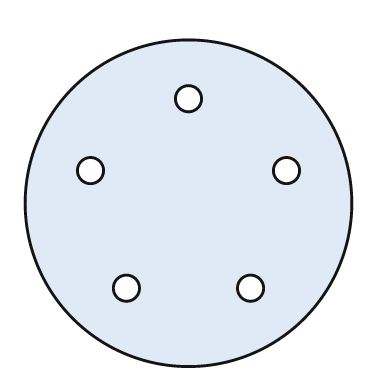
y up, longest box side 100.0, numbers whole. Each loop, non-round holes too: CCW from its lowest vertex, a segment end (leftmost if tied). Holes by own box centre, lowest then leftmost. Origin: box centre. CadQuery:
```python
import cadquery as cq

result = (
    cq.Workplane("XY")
    .moveTo(0.0, 0.0)
    .circle(50.0)
    .moveTo(-19.0, -26.0)
    .circle(4.0)
    .moveTo(19.0, -26.0)
    .circle(4.0)
    .moveTo(-30.0, 10.0)
    .circle(4.0)
    .moveTo(30.0, 10.0)
    .circle(4.0)
    .moveTo(0.0, 32.0)
    .circle(4.0)
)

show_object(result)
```